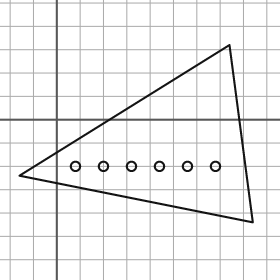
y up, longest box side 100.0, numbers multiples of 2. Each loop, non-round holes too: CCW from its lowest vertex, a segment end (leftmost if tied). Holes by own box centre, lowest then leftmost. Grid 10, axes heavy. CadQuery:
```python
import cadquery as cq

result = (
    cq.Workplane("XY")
    .moveTo(84.0, -44.0)
    .lineTo(74.0, 32.0)
    .lineTo(-16.0, -24.0)
    .close()
    .moveTo(8.0, -20.0)
    .circle(2.0)
    .moveTo(20.0, -20.0)
    .circle(2.0)
    .moveTo(32.0, -20.0)
    .circle(2.0)
    .moveTo(44.0, -20.0)
    .circle(2.0)
    .moveTo(56.0, -20.0)
    .circle(2.0)
    .moveTo(68.0, -20.0)
    .circle(2.0)
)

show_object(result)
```